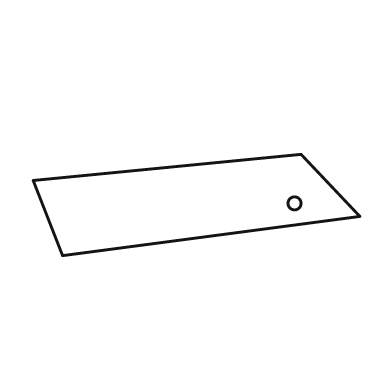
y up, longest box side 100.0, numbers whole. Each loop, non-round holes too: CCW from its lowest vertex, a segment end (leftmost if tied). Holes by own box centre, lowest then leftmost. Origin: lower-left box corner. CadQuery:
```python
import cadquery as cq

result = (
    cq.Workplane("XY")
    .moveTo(9.0, 0.0)
    .lineTo(100.0, 12.0)
    .lineTo(82.0, 31.0)
    .lineTo(0.0, 23.0)
    .close()
    .moveTo(80.0, 16.0)
    .circle(2.0)
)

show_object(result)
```